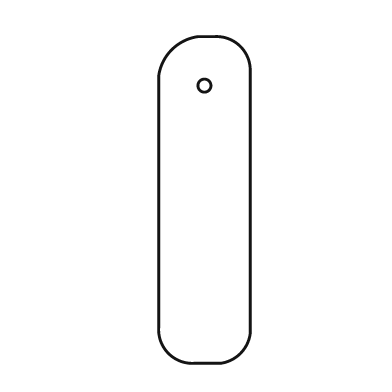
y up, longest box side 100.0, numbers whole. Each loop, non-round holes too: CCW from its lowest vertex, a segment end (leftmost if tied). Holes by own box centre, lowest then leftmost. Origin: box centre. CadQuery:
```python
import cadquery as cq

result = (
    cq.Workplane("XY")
    .moveTo(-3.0, -50.0)
    .lineTo(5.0, -50.0)
    .threePointArc((11.0, -47.0), (14.0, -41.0))
    .lineTo(14.0, 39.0)
    .threePointArc((11.0, 47.0), (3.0, 50.0))
    .lineTo(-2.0, 50.0)
    .threePointArc((-10.0, 46.0), (-14.0, 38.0))
    .lineTo(-14.0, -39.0)
    .threePointArc((-11.0, -47.0), (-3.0, -50.0))
    .close()
    .moveTo(0.0, 35.0)
    .circle(2.0)
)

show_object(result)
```